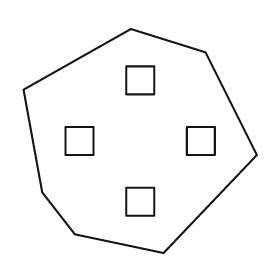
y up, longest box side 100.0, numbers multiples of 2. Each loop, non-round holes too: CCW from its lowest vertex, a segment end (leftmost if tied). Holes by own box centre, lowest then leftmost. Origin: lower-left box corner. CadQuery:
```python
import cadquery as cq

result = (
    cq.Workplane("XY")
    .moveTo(60.0, 0.0)
    .lineTo(100.0, 42.0)
    .lineTo(78.0, 86.0)
    .lineTo(46.0, 96.0)
    .lineTo(0.0, 70.0)
    .lineTo(8.0, 26.0)
    .lineTo(22.0, 8.0)
    .close()
    .moveTo(44.0, 16.0)
    .lineTo(56.0, 16.0)
    .lineTo(56.0, 28.0)
    .lineTo(44.0, 28.0)
    .close()
    .moveTo(18.0, 42.0)
    .lineTo(30.0, 42.0)
    .lineTo(30.0, 54.0)
    .lineTo(18.0, 54.0)
    .close()
    .moveTo(70.0, 42.0)
    .lineTo(82.0, 42.0)
    .lineTo(82.0, 54.0)
    .lineTo(70.0, 54.0)
    .close()
    .moveTo(44.0, 68.0)
    .lineTo(56.0, 68.0)
    .lineTo(56.0, 80.0)
    .lineTo(44.0, 80.0)
    .close()
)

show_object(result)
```